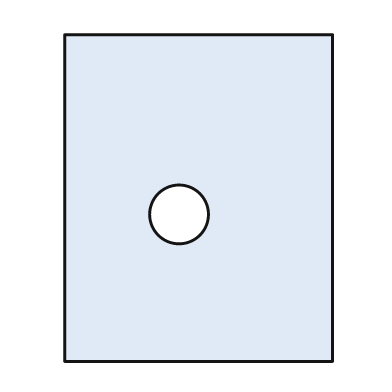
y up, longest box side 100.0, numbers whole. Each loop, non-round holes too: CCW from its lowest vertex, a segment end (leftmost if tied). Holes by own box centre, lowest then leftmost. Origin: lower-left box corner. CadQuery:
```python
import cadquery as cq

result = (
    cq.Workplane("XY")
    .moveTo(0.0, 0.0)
    .lineTo(82.0, 0.0)
    .lineTo(82.0, 100.0)
    .lineTo(0.0, 100.0)
    .close()
    .moveTo(35.0, 45.0)
    .circle(9.0)
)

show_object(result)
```